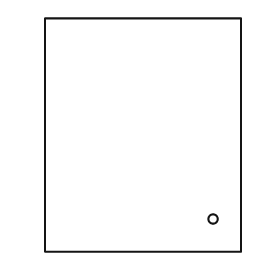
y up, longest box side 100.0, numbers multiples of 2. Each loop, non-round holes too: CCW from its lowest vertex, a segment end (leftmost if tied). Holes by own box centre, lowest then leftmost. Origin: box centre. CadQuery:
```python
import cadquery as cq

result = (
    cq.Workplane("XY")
    .moveTo(-42.0, -50.0)
    .lineTo(42.0, -50.0)
    .lineTo(42.0, 50.0)
    .lineTo(-42.0, 50.0)
    .close()
    .moveTo(30.0, -36.0)
    .circle(2.0)
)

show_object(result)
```